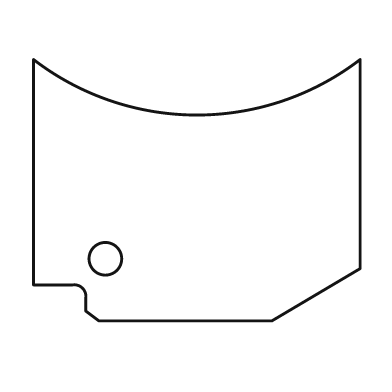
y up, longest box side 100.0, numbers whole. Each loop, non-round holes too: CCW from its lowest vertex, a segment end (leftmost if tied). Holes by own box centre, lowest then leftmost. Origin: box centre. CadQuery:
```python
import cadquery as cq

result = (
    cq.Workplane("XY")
    .moveTo(-30.0, -40.0)
    .lineTo(23.0, -40.0)
    .lineTo(50.0, -24.0)
    .lineTo(50.0, 40.0)
    .threePointArc((0.0, 23.0), (-50.0, 40.0))
    .lineTo(-50.0, -29.0)
    .lineTo(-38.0, -29.0)
    .threePointArc((-35.0, -30.0), (-34.0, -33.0))
    .lineTo(-34.0, -37.0)
    .close()
    .moveTo(-28.0, -21.0)
    .circle(5.0)
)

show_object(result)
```